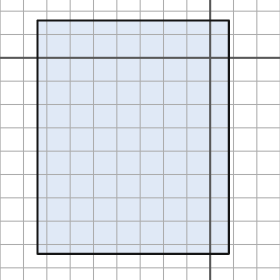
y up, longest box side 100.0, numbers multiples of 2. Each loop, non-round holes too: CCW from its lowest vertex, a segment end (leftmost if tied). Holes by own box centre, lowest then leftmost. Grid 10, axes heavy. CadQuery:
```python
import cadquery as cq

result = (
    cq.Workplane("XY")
    .moveTo(-74.0, -84.0)
    .lineTo(8.0, -84.0)
    .lineTo(8.0, 16.0)
    .lineTo(-74.0, 16.0)
    .close()
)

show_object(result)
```